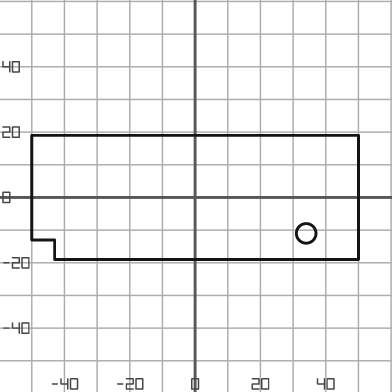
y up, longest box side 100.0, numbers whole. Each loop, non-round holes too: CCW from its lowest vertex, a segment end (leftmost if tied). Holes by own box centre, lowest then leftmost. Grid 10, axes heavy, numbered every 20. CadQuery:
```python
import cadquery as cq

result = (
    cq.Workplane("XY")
    .moveTo(-43.0, -19.0)
    .lineTo(50.0, -19.0)
    .lineTo(50.0, 19.0)
    .lineTo(-50.0, 19.0)
    .lineTo(-50.0, -13.0)
    .lineTo(-43.0, -13.0)
    .close()
    .moveTo(34.0, -11.0)
    .circle(3.0)
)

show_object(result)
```